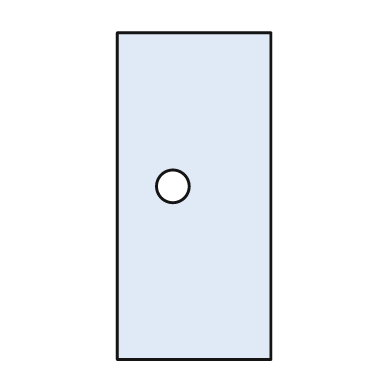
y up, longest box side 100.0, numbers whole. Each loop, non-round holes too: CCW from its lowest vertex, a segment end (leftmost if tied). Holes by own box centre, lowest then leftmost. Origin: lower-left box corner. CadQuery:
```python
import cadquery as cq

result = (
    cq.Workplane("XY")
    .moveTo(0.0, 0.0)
    .lineTo(47.0, 0.0)
    .lineTo(47.0, 100.0)
    .lineTo(0.0, 100.0)
    .close()
    .moveTo(17.0, 53.0)
    .circle(5.0)
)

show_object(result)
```